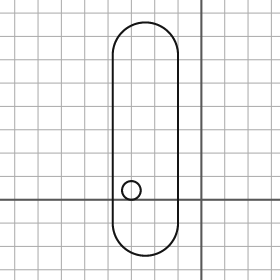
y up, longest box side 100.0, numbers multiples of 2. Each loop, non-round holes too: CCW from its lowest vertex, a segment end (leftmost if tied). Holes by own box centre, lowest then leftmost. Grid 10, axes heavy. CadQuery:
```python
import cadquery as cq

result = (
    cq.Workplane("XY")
    .moveTo(-38.0, -10.0)
    .threePointArc((-24.0, -24.0), (-10.0, -10.0))
    .lineTo(-10.0, 62.0)
    .threePointArc((-24.0, 76.0), (-38.0, 62.0))
    .close()
    .moveTo(-30.0, 4.0)
    .circle(4.0)
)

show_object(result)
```